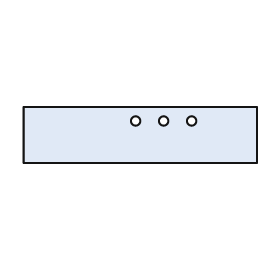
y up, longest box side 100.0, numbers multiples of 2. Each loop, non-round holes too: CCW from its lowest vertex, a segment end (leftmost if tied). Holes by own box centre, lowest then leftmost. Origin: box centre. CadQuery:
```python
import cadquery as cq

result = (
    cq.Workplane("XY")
    .moveTo(-50.0, -12.0)
    .lineTo(50.0, -12.0)
    .lineTo(50.0, 12.0)
    .lineTo(-50.0, 12.0)
    .close()
    .moveTo(-2.0, 6.0)
    .circle(2.0)
    .moveTo(10.0, 6.0)
    .circle(2.0)
    .moveTo(22.0, 6.0)
    .circle(2.0)
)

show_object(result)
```